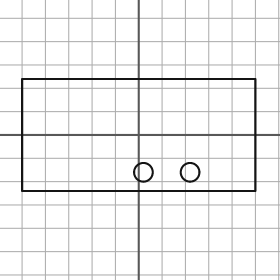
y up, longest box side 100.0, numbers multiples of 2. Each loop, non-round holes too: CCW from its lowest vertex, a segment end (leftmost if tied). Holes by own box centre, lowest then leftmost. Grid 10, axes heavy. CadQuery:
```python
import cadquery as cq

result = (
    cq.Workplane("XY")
    .moveTo(-50.0, -24.0)
    .lineTo(50.0, -24.0)
    .lineTo(50.0, 24.0)
    .lineTo(-50.0, 24.0)
    .close()
    .moveTo(2.0, -16.0)
    .circle(4.0)
    .moveTo(22.0, -16.0)
    .circle(4.0)
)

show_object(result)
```